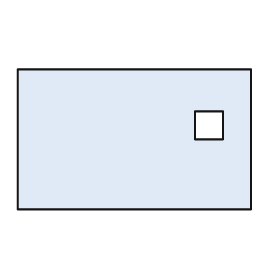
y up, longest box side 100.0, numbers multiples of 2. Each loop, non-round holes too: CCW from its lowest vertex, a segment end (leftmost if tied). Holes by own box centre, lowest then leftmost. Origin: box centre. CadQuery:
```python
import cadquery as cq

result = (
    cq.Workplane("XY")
    .moveTo(-50.0, -30.0)
    .lineTo(50.0, -30.0)
    .lineTo(50.0, 30.0)
    .lineTo(-50.0, 30.0)
    .close()
    .moveTo(26.0, 0.0)
    .lineTo(38.0, 0.0)
    .lineTo(38.0, 12.0)
    .lineTo(26.0, 12.0)
    .close()
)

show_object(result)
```